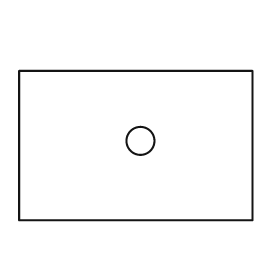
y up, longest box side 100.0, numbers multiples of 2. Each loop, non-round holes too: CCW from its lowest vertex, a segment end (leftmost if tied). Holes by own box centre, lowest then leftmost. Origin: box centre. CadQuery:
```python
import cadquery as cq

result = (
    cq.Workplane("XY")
    .moveTo(-50.0, -32.0)
    .lineTo(50.0, -32.0)
    .lineTo(50.0, 32.0)
    .lineTo(-50.0, 32.0)
    .close()
    .moveTo(2.0, 2.0)
    .circle(6.0)
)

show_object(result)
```